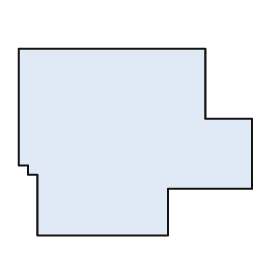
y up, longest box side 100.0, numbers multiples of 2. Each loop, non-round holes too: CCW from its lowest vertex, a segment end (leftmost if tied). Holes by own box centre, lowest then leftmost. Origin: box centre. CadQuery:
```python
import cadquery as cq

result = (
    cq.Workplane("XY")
    .moveTo(-42.0, -40.0)
    .lineTo(14.0, -40.0)
    .lineTo(14.0, -20.0)
    .lineTo(50.0, -20.0)
    .lineTo(50.0, 10.0)
    .lineTo(30.0, 10.0)
    .lineTo(30.0, 40.0)
    .lineTo(-50.0, 40.0)
    .lineTo(-50.0, -10.0)
    .lineTo(-46.0, -10.0)
    .lineTo(-46.0, -14.0)
    .lineTo(-42.0, -14.0)
    .close()
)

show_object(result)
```